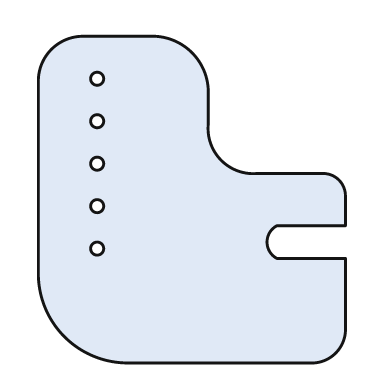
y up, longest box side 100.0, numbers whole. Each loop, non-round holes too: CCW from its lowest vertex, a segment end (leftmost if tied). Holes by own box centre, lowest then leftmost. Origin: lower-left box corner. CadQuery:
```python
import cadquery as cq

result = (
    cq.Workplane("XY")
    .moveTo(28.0, 0.0)
    .lineTo(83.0, 0.0)
    .threePointArc((91.0, 3.0), (94.0, 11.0))
    .lineTo(94.0, 32.0)
    .lineTo(73.0, 32.0)
    .threePointArc((70.0, 37.0), (73.0, 42.0))
    .lineTo(94.0, 42.0)
    .lineTo(94.0, 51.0)
    .threePointArc((92.0, 56.0), (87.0, 58.0))
    .lineTo(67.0, 58.0)
    .threePointArc((56.0, 62.0), (52.0, 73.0))
    .lineTo(52.0, 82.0)
    .threePointArc((47.0, 95.0), (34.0, 100.0))
    .lineTo(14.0, 100.0)
    .threePointArc((4.0, 96.0), (0.0, 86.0))
    .lineTo(0.0, 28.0)
    .threePointArc((8.0, 8.0), (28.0, 0.0))
    .close()
    .moveTo(18.0, 35.0)
    .circle(2.0)
    .moveTo(18.0, 48.0)
    .circle(2.0)
    .moveTo(18.0, 61.0)
    .circle(2.0)
    .moveTo(18.0, 74.0)
    .circle(2.0)
    .moveTo(18.0, 87.0)
    .circle(2.0)
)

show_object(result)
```